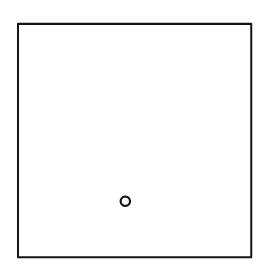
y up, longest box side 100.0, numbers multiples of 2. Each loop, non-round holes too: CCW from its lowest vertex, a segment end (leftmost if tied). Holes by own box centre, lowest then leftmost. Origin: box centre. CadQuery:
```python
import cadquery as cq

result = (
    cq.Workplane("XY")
    .moveTo(-50.0, -50.0)
    .lineTo(50.0, -50.0)
    .lineTo(50.0, 50.0)
    .lineTo(-50.0, 50.0)
    .close()
    .moveTo(-4.0, -26.0)
    .circle(2.0)
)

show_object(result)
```